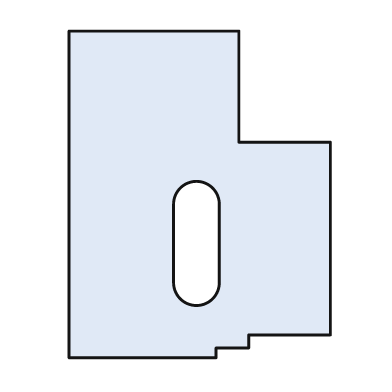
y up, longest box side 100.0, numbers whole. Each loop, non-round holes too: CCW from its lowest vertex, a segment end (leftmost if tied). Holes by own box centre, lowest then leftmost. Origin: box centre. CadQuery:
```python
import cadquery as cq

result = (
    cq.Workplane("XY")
    .moveTo(-40.0, -50.0)
    .lineTo(5.0, -50.0)
    .lineTo(5.0, -47.0)
    .lineTo(15.0, -47.0)
    .lineTo(15.0, -43.0)
    .lineTo(40.0, -43.0)
    .lineTo(40.0, 16.0)
    .lineTo(12.0, 16.0)
    .lineTo(12.0, 50.0)
    .lineTo(-40.0, 50.0)
    .close()
    .moveTo(-8.0, -27.0)
    .threePointArc((-1.0, -34.0), (6.0, -27.0))
    .lineTo(6.0, -3.0)
    .threePointArc((-1.0, 4.0), (-8.0, -3.0))
    .close()
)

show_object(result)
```